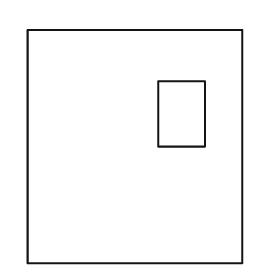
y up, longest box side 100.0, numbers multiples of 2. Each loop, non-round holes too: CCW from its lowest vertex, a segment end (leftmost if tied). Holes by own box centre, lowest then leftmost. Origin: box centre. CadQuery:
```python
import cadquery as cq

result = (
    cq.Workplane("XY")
    .moveTo(-46.0, -50.0)
    .lineTo(46.0, -50.0)
    .lineTo(46.0, 50.0)
    .lineTo(-46.0, 50.0)
    .close()
    .moveTo(10.0, 0.0)
    .lineTo(30.0, 0.0)
    .lineTo(30.0, 28.0)
    .lineTo(10.0, 28.0)
    .close()
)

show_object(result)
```